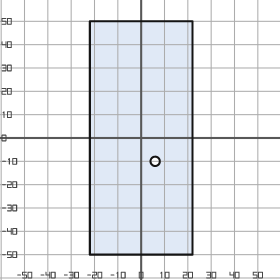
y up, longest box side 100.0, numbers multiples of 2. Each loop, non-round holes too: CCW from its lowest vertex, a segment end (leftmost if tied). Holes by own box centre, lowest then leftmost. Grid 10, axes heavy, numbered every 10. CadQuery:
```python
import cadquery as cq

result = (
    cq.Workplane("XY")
    .moveTo(-22.0, -50.0)
    .lineTo(22.0, -50.0)
    .lineTo(22.0, 50.0)
    .lineTo(-22.0, 50.0)
    .close()
    .moveTo(6.0, -10.0)
    .circle(2.0)
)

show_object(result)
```